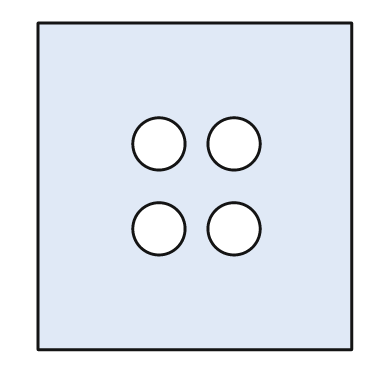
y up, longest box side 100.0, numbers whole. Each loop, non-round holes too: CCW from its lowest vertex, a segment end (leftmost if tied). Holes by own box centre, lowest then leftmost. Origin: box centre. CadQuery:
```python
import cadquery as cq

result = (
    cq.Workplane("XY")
    .moveTo(-48.0, -50.0)
    .lineTo(48.0, -50.0)
    .lineTo(48.0, 50.0)
    .lineTo(-48.0, 50.0)
    .close()
    .moveTo(-11.0, -13.0)
    .circle(8.0)
    .moveTo(12.0, -13.0)
    .circle(8.0)
    .moveTo(-11.0, 13.0)
    .circle(8.0)
    .moveTo(12.0, 13.0)
    .circle(8.0)
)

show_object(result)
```